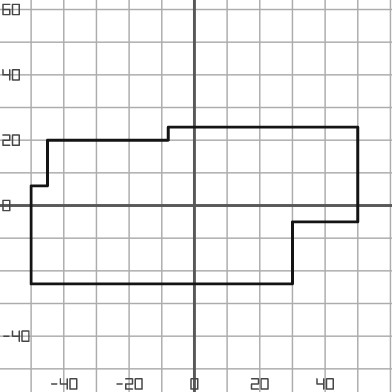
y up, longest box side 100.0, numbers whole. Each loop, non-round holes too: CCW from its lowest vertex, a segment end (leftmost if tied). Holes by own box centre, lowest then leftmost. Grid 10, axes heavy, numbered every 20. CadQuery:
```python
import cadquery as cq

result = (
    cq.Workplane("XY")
    .moveTo(-50.0, -24.0)
    .lineTo(30.0, -24.0)
    .lineTo(30.0, -5.0)
    .lineTo(50.0, -5.0)
    .lineTo(50.0, 24.0)
    .lineTo(-8.0, 24.0)
    .lineTo(-8.0, 20.0)
    .lineTo(-45.0, 20.0)
    .lineTo(-45.0, 6.0)
    .lineTo(-50.0, 6.0)
    .close()
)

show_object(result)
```